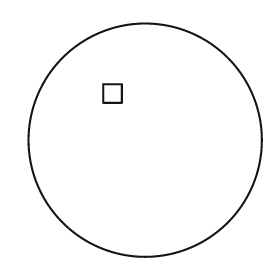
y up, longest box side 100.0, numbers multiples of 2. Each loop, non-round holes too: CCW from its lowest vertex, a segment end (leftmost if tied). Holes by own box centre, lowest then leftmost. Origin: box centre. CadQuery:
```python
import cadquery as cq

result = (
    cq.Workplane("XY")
    .moveTo(0.0, 0.0)
    .circle(50.0)
    .moveTo(-18.0, 16.0)
    .lineTo(-10.0, 16.0)
    .lineTo(-10.0, 24.0)
    .lineTo(-18.0, 24.0)
    .close()
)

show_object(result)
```